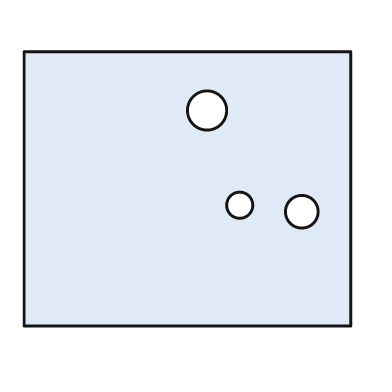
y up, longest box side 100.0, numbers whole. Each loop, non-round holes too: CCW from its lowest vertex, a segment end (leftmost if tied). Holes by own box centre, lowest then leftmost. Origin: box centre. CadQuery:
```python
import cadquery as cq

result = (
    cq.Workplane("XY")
    .moveTo(-50.0, -42.0)
    .lineTo(50.0, -42.0)
    .lineTo(50.0, 42.0)
    .lineTo(-50.0, 42.0)
    .close()
    .moveTo(35.0, -7.0)
    .circle(5.0)
    .moveTo(16.0, -5.0)
    .circle(4.0)
    .moveTo(6.0, 24.0)
    .circle(6.0)
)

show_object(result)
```